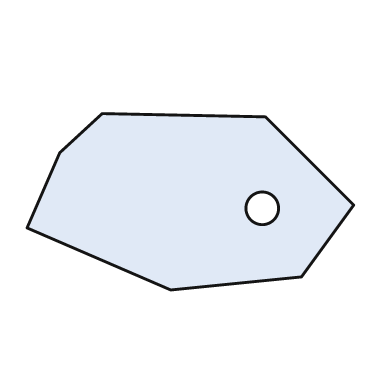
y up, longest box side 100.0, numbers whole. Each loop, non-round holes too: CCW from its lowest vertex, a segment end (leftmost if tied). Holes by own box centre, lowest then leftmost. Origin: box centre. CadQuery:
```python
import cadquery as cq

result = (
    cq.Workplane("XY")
    .moveTo(-6.0, -27.0)
    .lineTo(34.0, -23.0)
    .lineTo(50.0, -1.0)
    .lineTo(23.0, 26.0)
    .lineTo(-27.0, 27.0)
    .lineTo(-40.0, 15.0)
    .lineTo(-50.0, -8.0)
    .close()
    .moveTo(22.0, -2.0)
    .circle(5.0)
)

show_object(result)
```